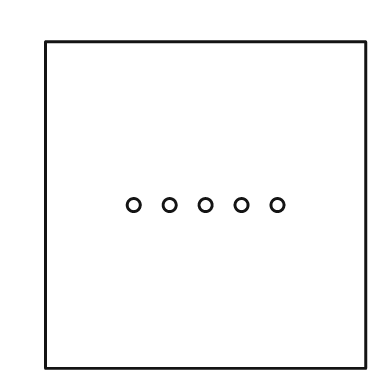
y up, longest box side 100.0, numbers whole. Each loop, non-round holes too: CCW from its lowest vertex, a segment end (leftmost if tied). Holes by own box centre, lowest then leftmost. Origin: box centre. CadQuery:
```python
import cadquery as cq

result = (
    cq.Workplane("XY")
    .moveTo(-49.0, -50.0)
    .lineTo(49.0, -50.0)
    .lineTo(49.0, 50.0)
    .lineTo(-49.0, 50.0)
    .close()
    .moveTo(-22.0, 0.0)
    .circle(2.0)
    .moveTo(-11.0, 0.0)
    .circle(2.0)
    .moveTo(0.0, 0.0)
    .circle(2.0)
    .moveTo(11.0, 0.0)
    .circle(2.0)
    .moveTo(22.0, 0.0)
    .circle(2.0)
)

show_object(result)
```